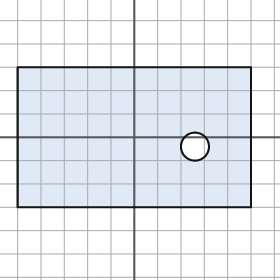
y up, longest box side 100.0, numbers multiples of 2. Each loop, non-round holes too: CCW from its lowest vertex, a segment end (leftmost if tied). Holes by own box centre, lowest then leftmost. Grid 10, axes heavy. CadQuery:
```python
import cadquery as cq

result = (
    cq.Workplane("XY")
    .moveTo(-50.0, -30.0)
    .lineTo(50.0, -30.0)
    .lineTo(50.0, 30.0)
    .lineTo(-50.0, 30.0)
    .close()
    .moveTo(26.0, -4.0)
    .circle(6.0)
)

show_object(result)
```